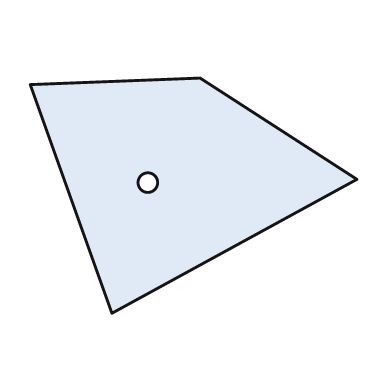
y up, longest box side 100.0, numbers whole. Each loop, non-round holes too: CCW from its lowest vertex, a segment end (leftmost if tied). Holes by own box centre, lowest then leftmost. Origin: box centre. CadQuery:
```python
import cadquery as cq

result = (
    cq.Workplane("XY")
    .moveTo(-25.0, -36.0)
    .lineTo(50.0, 5.0)
    .lineTo(2.0, 36.0)
    .lineTo(-50.0, 34.0)
    .close()
    .moveTo(-14.0, 4.0)
    .circle(3.0)
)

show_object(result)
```